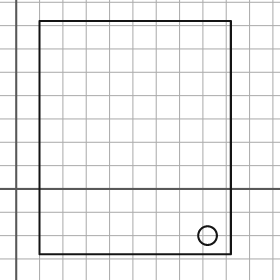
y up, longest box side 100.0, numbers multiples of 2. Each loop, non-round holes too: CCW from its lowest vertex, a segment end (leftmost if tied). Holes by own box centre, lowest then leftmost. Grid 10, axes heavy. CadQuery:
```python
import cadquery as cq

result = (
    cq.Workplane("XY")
    .moveTo(10.0, -28.0)
    .lineTo(92.0, -28.0)
    .lineTo(92.0, 72.0)
    .lineTo(10.0, 72.0)
    .close()
    .moveTo(82.0, -20.0)
    .circle(4.0)
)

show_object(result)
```